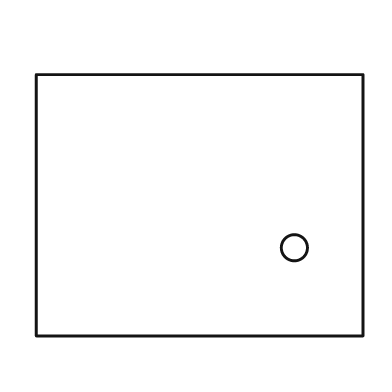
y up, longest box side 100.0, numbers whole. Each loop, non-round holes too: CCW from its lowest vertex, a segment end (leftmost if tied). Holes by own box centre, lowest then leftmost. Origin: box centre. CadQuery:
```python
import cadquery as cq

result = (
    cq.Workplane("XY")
    .moveTo(-50.0, -40.0)
    .lineTo(50.0, -40.0)
    .lineTo(50.0, 40.0)
    .lineTo(-50.0, 40.0)
    .close()
    .moveTo(29.0, -13.0)
    .circle(4.0)
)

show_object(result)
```